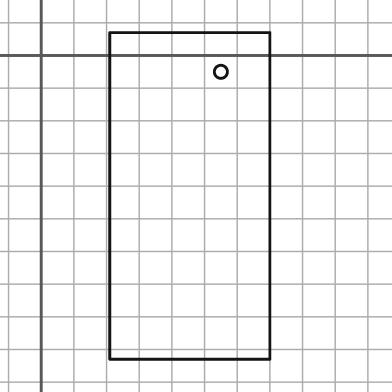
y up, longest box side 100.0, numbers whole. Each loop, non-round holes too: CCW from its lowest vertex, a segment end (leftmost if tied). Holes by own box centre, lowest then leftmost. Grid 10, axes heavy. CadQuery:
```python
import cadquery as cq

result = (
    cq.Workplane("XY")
    .moveTo(21.0, -93.0)
    .lineTo(70.0, -93.0)
    .lineTo(70.0, 7.0)
    .lineTo(21.0, 7.0)
    .close()
    .moveTo(55.0, -5.0)
    .circle(2.0)
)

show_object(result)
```